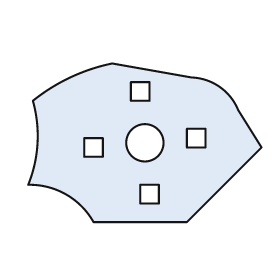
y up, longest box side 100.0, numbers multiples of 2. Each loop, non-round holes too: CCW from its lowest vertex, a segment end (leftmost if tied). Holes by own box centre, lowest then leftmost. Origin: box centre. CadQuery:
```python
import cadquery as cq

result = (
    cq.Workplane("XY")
    .moveTo(-22.0, -34.0)
    .lineTo(18.0, -34.0)
    .lineTo(50.0, -2.0)
    .lineTo(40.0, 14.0)
    .threePointArc((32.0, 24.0), (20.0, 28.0))
    .lineTo(-14.0, 34.0)
    .threePointArc((-32.0, 28.0), (-48.0, 18.0))
    .threePointArc((-46.0, 0.0), (-50.0, -18.0))
    .threePointArc((-34.0, -22.0), (-22.0, -34.0))
    .close()
    .moveTo(-2.0, -26.0)
    .lineTo(6.0, -26.0)
    .lineTo(6.0, -18.0)
    .lineTo(-2.0, -18.0)
    .close()
    .moveTo(-26.0, -6.0)
    .lineTo(-18.0, -6.0)
    .lineTo(-18.0, 2.0)
    .lineTo(-26.0, 2.0)
    .close()
    .moveTo(0.0, 0.0)
    .circle(8.0)
    .moveTo(18.0, -2.0)
    .lineTo(26.0, -2.0)
    .lineTo(26.0, 6.0)
    .lineTo(18.0, 6.0)
    .close()
    .moveTo(-6.0, 18.0)
    .lineTo(2.0, 18.0)
    .lineTo(2.0, 26.0)
    .lineTo(-6.0, 26.0)
    .close()
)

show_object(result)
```